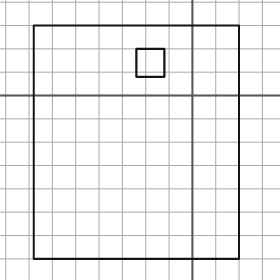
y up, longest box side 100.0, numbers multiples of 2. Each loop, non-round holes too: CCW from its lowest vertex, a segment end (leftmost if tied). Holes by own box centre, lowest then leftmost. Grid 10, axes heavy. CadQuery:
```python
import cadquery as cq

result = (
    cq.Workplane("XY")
    .moveTo(-68.0, -70.0)
    .lineTo(20.0, -70.0)
    .lineTo(20.0, 30.0)
    .lineTo(-68.0, 30.0)
    .close()
    .moveTo(-24.0, 8.0)
    .lineTo(-12.0, 8.0)
    .lineTo(-12.0, 20.0)
    .lineTo(-24.0, 20.0)
    .close()
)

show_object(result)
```